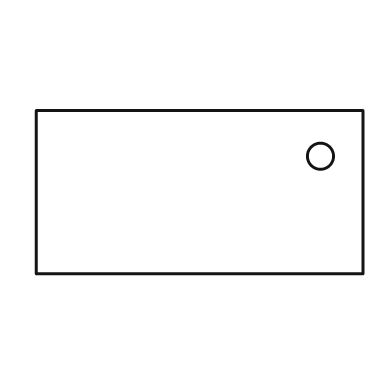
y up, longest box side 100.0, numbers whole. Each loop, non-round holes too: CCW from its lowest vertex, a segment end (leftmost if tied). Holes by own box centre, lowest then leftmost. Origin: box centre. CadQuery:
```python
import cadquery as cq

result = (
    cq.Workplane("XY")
    .moveTo(-50.0, -25.0)
    .lineTo(50.0, -25.0)
    .lineTo(50.0, 25.0)
    .lineTo(-50.0, 25.0)
    .close()
    .moveTo(37.0, 11.0)
    .circle(4.0)
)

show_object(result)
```